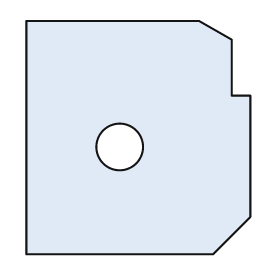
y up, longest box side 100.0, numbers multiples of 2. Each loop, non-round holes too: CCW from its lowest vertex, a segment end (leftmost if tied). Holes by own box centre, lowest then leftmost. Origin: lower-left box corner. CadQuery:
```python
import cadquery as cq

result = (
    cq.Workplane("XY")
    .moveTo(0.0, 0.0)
    .lineTo(80.0, 0.0)
    .lineTo(96.0, 16.0)
    .lineTo(96.0, 68.0)
    .lineTo(88.0, 68.0)
    .lineTo(88.0, 92.0)
    .lineTo(74.0, 100.0)
    .lineTo(0.0, 100.0)
    .close()
    .moveTo(40.0, 46.0)
    .circle(10.0)
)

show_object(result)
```